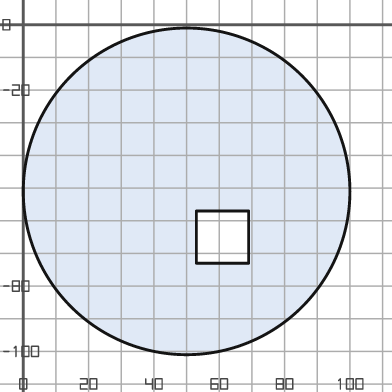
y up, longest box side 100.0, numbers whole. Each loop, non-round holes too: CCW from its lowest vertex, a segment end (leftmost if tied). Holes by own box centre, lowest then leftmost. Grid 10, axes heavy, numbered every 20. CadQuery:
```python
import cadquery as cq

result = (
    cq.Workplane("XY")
    .moveTo(50.0, -51.0)
    .circle(50.0)
    .moveTo(53.0, -73.0)
    .lineTo(69.0, -73.0)
    .lineTo(69.0, -57.0)
    .lineTo(53.0, -57.0)
    .close()
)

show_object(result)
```